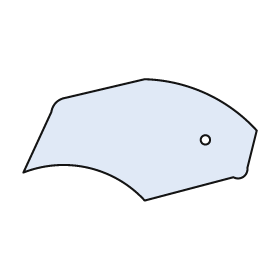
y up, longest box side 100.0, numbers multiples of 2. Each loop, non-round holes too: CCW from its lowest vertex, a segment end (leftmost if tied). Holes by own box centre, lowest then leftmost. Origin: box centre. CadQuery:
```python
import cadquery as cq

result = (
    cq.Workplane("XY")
    .moveTo(2.0, -26.0)
    .lineTo(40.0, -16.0)
    .threePointArc((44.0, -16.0), (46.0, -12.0))
    .lineTo(50.0, 4.0)
    .threePointArc((28.0, 20.0), (2.0, 26.0))
    .lineTo(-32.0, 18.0)
    .threePointArc((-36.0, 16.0), (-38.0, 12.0))
    .lineTo(-50.0, -14.0)
    .threePointArc((-22.0, -12.0), (2.0, -26.0))
    .close()
    .moveTo(28.0, 0.0)
    .circle(2.0)
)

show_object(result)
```